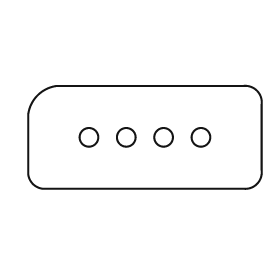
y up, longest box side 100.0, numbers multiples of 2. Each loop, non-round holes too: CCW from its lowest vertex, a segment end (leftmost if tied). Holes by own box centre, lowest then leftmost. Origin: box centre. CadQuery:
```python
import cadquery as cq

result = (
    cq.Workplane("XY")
    .moveTo(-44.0, -22.0)
    .lineTo(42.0, -22.0)
    .threePointArc((48.0, -20.0), (50.0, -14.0))
    .lineTo(50.0, 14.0)
    .threePointArc((48.0, 20.0), (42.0, 22.0))
    .lineTo(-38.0, 22.0)
    .threePointArc((-46.0, 18.0), (-50.0, 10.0))
    .lineTo(-50.0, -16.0)
    .threePointArc((-48.0, -20.0), (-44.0, -22.0))
    .close()
    .moveTo(-24.0, 0.0)
    .circle(4.0)
    .moveTo(-8.0, 0.0)
    .circle(4.0)
    .moveTo(8.0, 0.0)
    .circle(4.0)
    .moveTo(24.0, 0.0)
    .circle(4.0)
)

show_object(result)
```